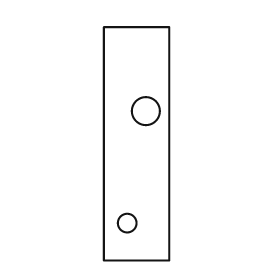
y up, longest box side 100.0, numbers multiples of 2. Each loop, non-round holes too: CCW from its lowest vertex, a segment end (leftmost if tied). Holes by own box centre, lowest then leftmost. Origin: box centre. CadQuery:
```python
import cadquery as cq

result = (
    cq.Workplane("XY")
    .moveTo(-14.0, -50.0)
    .lineTo(14.0, -50.0)
    .lineTo(14.0, 50.0)
    .lineTo(-14.0, 50.0)
    .close()
    .moveTo(-4.0, -34.0)
    .circle(4.0)
    .moveTo(4.0, 14.0)
    .circle(6.0)
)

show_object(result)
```